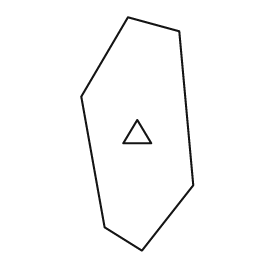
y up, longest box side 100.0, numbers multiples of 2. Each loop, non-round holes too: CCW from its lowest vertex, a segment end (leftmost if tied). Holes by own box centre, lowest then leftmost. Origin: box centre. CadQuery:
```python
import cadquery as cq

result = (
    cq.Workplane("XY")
    .moveTo(2.0, -50.0)
    .lineTo(24.0, -22.0)
    .lineTo(18.0, 44.0)
    .lineTo(-4.0, 50.0)
    .lineTo(-24.0, 16.0)
    .lineTo(-14.0, -40.0)
    .close()
    .moveTo(-6.0, -4.0)
    .lineTo(6.0, -4.0)
    .lineTo(0.0, 6.0)
    .close()
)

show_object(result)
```